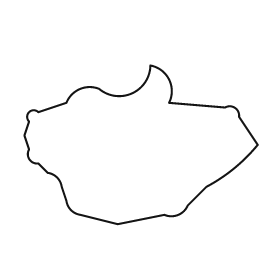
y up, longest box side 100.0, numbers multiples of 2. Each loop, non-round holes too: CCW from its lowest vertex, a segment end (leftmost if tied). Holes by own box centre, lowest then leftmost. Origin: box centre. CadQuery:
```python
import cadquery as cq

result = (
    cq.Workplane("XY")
    .moveTo(-10.0, -34.0)
    .lineTo(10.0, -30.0)
    .threePointArc((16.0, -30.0), (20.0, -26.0))
    .lineTo(28.0, -18.0)
    .threePointArc((40.0, -10.0), (50.0, 0.0))
    .lineTo(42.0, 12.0)
    .threePointArc((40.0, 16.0), (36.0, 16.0))
    .lineTo(12.0, 18.0)
    .threePointArc((12.0, 28.0), (4.0, 34.0))
    .threePointArc((-4.0, 22.0), (-18.0, 24.0))
    .threePointArc((-26.0, 24.0), (-32.0, 18.0))
    .lineTo(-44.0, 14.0)
    .threePointArc((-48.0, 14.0), (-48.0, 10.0))
    .lineTo(-50.0, 4.0)
    .lineTo(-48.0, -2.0)
    .threePointArc((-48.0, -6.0), (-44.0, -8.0))
    .lineTo(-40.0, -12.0)
    .threePointArc((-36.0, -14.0), (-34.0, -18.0))
    .lineTo(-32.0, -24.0)
    .threePointArc((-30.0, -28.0), (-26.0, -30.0))
    .close()
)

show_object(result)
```